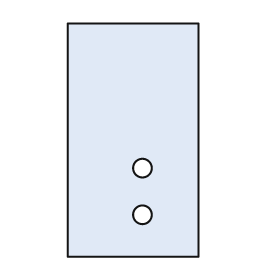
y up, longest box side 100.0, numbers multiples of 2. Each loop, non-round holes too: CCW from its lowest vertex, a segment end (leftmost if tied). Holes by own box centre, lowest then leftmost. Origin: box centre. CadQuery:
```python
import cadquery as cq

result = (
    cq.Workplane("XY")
    .moveTo(-28.0, -50.0)
    .lineTo(28.0, -50.0)
    .lineTo(28.0, 50.0)
    .lineTo(-28.0, 50.0)
    .close()
    .moveTo(4.0, -32.0)
    .circle(4.0)
    .moveTo(4.0, -12.0)
    .circle(4.0)
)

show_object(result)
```